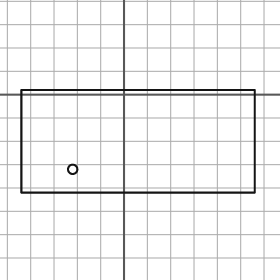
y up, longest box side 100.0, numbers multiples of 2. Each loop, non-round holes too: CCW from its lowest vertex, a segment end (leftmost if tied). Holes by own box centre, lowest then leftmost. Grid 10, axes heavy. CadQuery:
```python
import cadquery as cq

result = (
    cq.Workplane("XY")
    .moveTo(-44.0, -42.0)
    .lineTo(56.0, -42.0)
    .lineTo(56.0, 2.0)
    .lineTo(-44.0, 2.0)
    .close()
    .moveTo(-22.0, -32.0)
    .circle(2.0)
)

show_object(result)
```